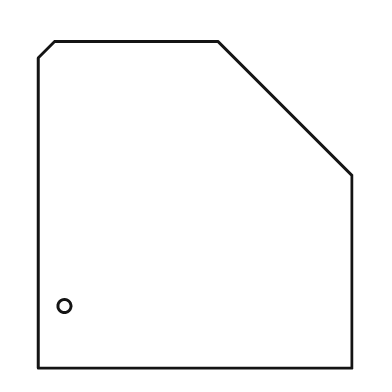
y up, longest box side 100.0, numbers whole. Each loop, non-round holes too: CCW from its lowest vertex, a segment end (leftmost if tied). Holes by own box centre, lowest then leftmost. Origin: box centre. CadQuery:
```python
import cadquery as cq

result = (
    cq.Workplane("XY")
    .moveTo(-48.0, -50.0)
    .lineTo(48.0, -50.0)
    .lineTo(48.0, 9.0)
    .lineTo(7.0, 50.0)
    .lineTo(-43.0, 50.0)
    .lineTo(-48.0, 45.0)
    .close()
    .moveTo(-40.0, -31.0)
    .circle(2.0)
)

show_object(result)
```